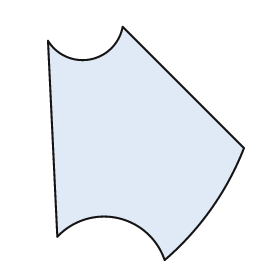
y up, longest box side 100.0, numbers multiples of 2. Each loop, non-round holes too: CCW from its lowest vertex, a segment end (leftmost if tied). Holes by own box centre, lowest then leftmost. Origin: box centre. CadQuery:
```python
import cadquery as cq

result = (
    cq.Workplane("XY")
    .moveTo(8.0, -50.0)
    .threePointArc((28.0, -28.0), (42.0, -2.0))
    .lineTo(-10.0, 50.0)
    .threePointArc((-24.0, 36.0), (-42.0, 44.0))
    .lineTo(-38.0, -40.0)
    .threePointArc((-12.0, -32.0), (8.0, -50.0))
    .close()
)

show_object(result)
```